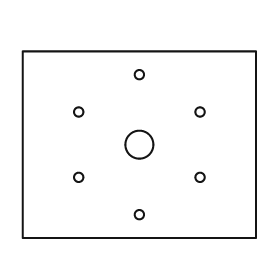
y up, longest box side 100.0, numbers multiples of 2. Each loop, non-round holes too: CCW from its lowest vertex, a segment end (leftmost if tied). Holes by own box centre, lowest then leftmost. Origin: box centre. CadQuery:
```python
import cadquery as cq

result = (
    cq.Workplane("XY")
    .moveTo(-50.0, -40.0)
    .lineTo(50.0, -40.0)
    .lineTo(50.0, 40.0)
    .lineTo(-50.0, 40.0)
    .close()
    .moveTo(0.0, -30.0)
    .circle(2.0)
    .moveTo(-26.0, -14.0)
    .circle(2.0)
    .moveTo(26.0, -14.0)
    .circle(2.0)
    .moveTo(0.0, 0.0)
    .circle(6.0)
    .moveTo(-26.0, 14.0)
    .circle(2.0)
    .moveTo(26.0, 14.0)
    .circle(2.0)
    .moveTo(0.0, 30.0)
    .circle(2.0)
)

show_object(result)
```